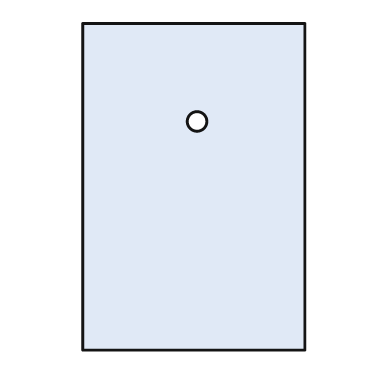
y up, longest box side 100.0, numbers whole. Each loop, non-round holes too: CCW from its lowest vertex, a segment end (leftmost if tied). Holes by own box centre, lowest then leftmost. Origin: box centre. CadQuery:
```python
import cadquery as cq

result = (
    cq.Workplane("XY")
    .moveTo(-34.0, -50.0)
    .lineTo(34.0, -50.0)
    .lineTo(34.0, 50.0)
    .lineTo(-34.0, 50.0)
    .close()
    .moveTo(1.0, 20.0)
    .circle(3.0)
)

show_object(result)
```